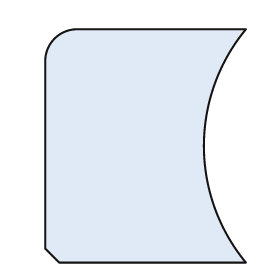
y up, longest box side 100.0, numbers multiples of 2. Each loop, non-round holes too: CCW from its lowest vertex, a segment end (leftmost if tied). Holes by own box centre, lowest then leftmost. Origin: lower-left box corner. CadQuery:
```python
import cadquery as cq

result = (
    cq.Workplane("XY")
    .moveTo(6.0, 0.0)
    .lineTo(86.0, 0.0)
    .threePointArc((68.0, 50.0), (86.0, 100.0))
    .lineTo(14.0, 100.0)
    .threePointArc((4.0, 96.0), (0.0, 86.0))
    .lineTo(0.0, 6.0)
    .close()
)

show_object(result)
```